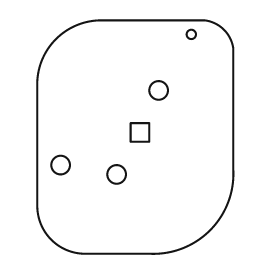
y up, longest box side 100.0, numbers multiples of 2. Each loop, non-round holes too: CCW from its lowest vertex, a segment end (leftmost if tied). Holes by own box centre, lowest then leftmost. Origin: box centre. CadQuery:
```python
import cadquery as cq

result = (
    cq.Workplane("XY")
    .moveTo(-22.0, -50.0)
    .lineTo(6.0, -50.0)
    .threePointArc((32.0, -40.0), (42.0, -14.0))
    .lineTo(42.0, 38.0)
    .threePointArc((38.0, 46.0), (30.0, 50.0))
    .lineTo(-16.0, 50.0)
    .threePointArc((-34.0, 42.0), (-42.0, 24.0))
    .lineTo(-42.0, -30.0)
    .threePointArc((-36.0, -44.0), (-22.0, -50.0))
    .close()
    .moveTo(-8.0, -16.0)
    .circle(4.0)
    .moveTo(-32.0, -12.0)
    .circle(4.0)
    .moveTo(-2.0, -2.0)
    .lineTo(6.0, -2.0)
    .lineTo(6.0, 6.0)
    .lineTo(-2.0, 6.0)
    .close()
    .moveTo(10.0, 20.0)
    .circle(4.0)
    .moveTo(24.0, 44.0)
    .circle(2.0)
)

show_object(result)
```